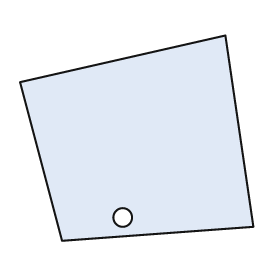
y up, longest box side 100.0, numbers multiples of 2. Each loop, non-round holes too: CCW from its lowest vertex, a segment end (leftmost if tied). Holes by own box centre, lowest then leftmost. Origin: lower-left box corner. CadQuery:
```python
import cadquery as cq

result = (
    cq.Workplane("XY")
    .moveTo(18.0, 0.0)
    .lineTo(100.0, 6.0)
    .lineTo(88.0, 88.0)
    .lineTo(0.0, 68.0)
    .close()
    .moveTo(44.0, 10.0)
    .circle(4.0)
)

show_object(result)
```